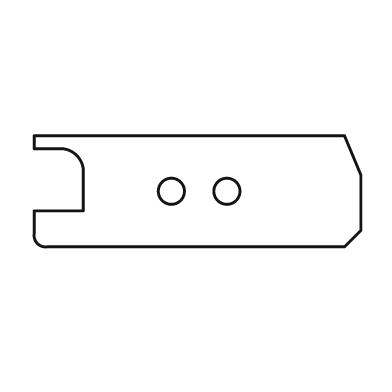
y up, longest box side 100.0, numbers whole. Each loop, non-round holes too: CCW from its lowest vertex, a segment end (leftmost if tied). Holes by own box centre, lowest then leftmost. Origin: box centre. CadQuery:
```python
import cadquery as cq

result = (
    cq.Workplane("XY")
    .moveTo(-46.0, -17.0)
    .lineTo(45.0, -17.0)
    .lineTo(50.0, -12.0)
    .lineTo(50.0, 5.0)
    .lineTo(45.0, 17.0)
    .lineTo(-50.0, 17.0)
    .lineTo(-50.0, 13.0)
    .lineTo(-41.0, 13.0)
    .threePointArc((-37.0, 11.0), (-35.0, 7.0))
    .lineTo(-35.0, -6.0)
    .lineTo(-50.0, -6.0)
    .lineTo(-50.0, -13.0)
    .threePointArc((-49.0, -16.0), (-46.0, -17.0))
    .close()
    .moveTo(-8.0, 0.0)
    .circle(4.0)
    .moveTo(9.0, 0.0)
    .circle(4.0)
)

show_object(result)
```